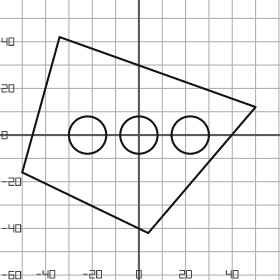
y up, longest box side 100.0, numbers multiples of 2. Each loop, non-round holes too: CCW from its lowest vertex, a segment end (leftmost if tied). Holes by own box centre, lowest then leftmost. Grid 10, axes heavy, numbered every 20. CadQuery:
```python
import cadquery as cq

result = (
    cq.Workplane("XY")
    .moveTo(4.0, -42.0)
    .lineTo(50.0, 12.0)
    .lineTo(-34.0, 42.0)
    .lineTo(-50.0, -16.0)
    .close()
    .moveTo(-22.0, 0.0)
    .circle(8.0)
    .moveTo(0.0, 0.0)
    .circle(8.0)
    .moveTo(22.0, 0.0)
    .circle(8.0)
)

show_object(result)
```